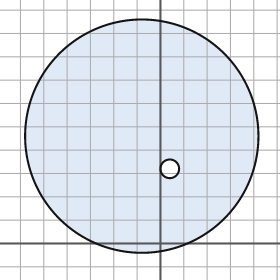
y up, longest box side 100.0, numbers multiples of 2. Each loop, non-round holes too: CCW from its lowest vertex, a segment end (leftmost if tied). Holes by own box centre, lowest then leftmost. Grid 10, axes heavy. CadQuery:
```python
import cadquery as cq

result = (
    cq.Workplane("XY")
    .moveTo(-8.0, 46.0)
    .circle(50.0)
    .moveTo(4.0, 32.0)
    .circle(4.0)
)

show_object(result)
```